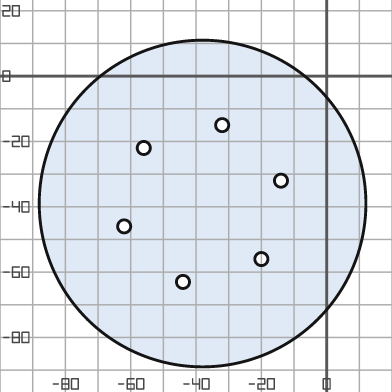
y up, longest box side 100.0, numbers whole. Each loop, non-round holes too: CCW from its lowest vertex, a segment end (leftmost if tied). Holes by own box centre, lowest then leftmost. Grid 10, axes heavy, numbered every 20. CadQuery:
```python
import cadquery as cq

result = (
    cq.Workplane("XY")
    .moveTo(-38.0, -39.0)
    .circle(50.0)
    .moveTo(-44.0, -63.0)
    .circle(2.0)
    .moveTo(-20.0, -56.0)
    .circle(2.0)
    .moveTo(-62.0, -46.0)
    .circle(2.0)
    .moveTo(-14.0, -32.0)
    .circle(2.0)
    .moveTo(-56.0, -22.0)
    .circle(2.0)
    .moveTo(-32.0, -15.0)
    .circle(2.0)
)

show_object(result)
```